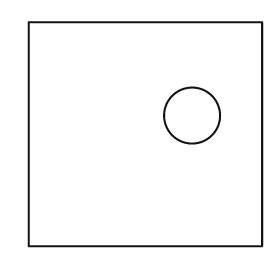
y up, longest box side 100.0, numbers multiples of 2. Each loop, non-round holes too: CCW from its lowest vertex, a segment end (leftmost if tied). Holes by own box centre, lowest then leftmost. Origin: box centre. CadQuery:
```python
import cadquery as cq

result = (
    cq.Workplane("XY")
    .moveTo(-50.0, -48.0)
    .lineTo(50.0, -48.0)
    .lineTo(50.0, 48.0)
    .lineTo(-50.0, 48.0)
    .close()
    .moveTo(20.0, 8.0)
    .circle(12.0)
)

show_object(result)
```